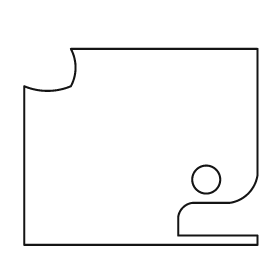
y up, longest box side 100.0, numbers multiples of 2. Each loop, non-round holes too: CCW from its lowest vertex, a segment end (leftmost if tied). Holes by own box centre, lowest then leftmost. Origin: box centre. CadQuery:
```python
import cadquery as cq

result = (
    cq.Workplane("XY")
    .moveTo(-50.0, -42.0)
    .lineTo(50.0, -42.0)
    .lineTo(50.0, -38.0)
    .lineTo(16.0, -38.0)
    .lineTo(16.0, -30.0)
    .threePointArc((18.0, -26.0), (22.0, -24.0))
    .lineTo(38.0, -24.0)
    .threePointArc((46.0, -20.0), (50.0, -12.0))
    .lineTo(50.0, 42.0)
    .lineTo(-30.0, 42.0)
    .threePointArc((-28.0, 34.0), (-30.0, 26.0))
    .threePointArc((-40.0, 24.0), (-50.0, 26.0))
    .close()
    .moveTo(28.0, -14.0)
    .circle(6.0)
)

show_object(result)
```